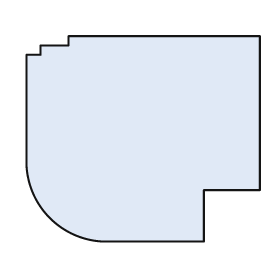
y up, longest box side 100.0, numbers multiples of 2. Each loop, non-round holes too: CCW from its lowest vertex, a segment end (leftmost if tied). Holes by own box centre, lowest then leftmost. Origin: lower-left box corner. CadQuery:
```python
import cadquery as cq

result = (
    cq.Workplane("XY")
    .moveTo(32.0, 0.0)
    .lineTo(76.0, 0.0)
    .lineTo(76.0, 22.0)
    .lineTo(100.0, 22.0)
    .lineTo(100.0, 88.0)
    .lineTo(18.0, 88.0)
    .lineTo(18.0, 84.0)
    .lineTo(6.0, 84.0)
    .lineTo(6.0, 80.0)
    .lineTo(0.0, 80.0)
    .lineTo(0.0, 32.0)
    .threePointArc((10.0, 10.0), (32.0, 0.0))
    .close()
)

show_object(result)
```